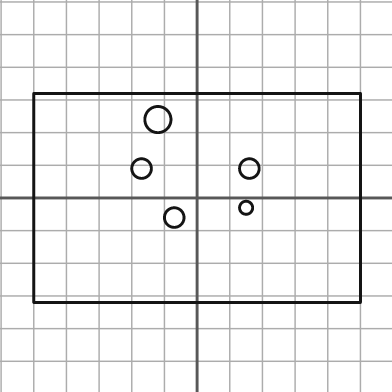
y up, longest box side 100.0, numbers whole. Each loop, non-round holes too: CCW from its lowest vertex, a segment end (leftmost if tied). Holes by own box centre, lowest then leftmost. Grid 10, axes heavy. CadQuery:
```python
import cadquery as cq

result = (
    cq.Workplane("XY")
    .moveTo(-50.0, -32.0)
    .lineTo(50.0, -32.0)
    .lineTo(50.0, 32.0)
    .lineTo(-50.0, 32.0)
    .close()
    .moveTo(-7.0, -6.0)
    .circle(3.0)
    .moveTo(15.0, -3.0)
    .circle(2.0)
    .moveTo(-17.0, 9.0)
    .circle(3.0)
    .moveTo(16.0, 9.0)
    .circle(3.0)
    .moveTo(-12.0, 24.0)
    .circle(4.0)
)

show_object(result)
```